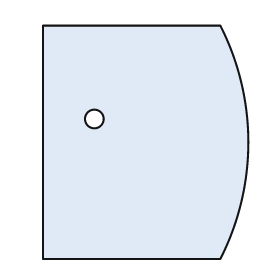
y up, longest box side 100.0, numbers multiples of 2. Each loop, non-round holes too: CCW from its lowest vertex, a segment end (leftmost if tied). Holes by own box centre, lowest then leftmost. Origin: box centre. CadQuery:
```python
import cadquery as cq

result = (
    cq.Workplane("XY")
    .moveTo(-44.0, -50.0)
    .lineTo(32.0, -50.0)
    .threePointArc((44.0, 0.0), (32.0, 50.0))
    .lineTo(-44.0, 50.0)
    .close()
    .moveTo(-22.0, 10.0)
    .circle(4.0)
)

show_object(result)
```